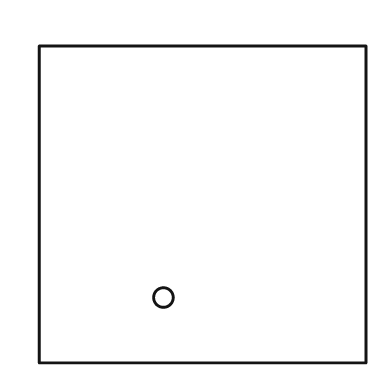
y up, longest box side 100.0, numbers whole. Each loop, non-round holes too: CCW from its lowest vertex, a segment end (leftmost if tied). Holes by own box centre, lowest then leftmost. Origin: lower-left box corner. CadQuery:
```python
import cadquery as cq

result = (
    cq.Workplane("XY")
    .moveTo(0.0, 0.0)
    .lineTo(100.0, 0.0)
    .lineTo(100.0, 97.0)
    .lineTo(0.0, 97.0)
    .close()
    .moveTo(38.0, 20.0)
    .circle(3.0)
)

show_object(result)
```